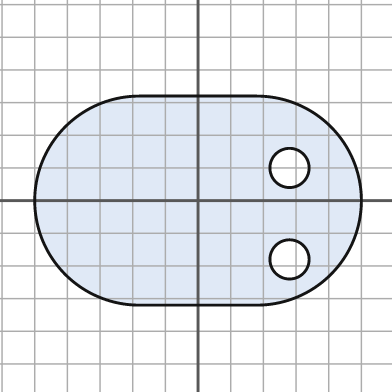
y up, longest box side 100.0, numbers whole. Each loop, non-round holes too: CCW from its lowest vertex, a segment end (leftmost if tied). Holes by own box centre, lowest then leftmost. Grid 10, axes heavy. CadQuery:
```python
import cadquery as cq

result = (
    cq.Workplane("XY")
    .moveTo(-18.0, -32.0)
    .lineTo(18.0, -32.0)
    .threePointArc((50.0, 0.0), (18.0, 32.0))
    .lineTo(-18.0, 32.0)
    .threePointArc((-50.0, 0.0), (-18.0, -32.0))
    .close()
    .moveTo(28.0, -18.0)
    .circle(6.0)
    .moveTo(28.0, 10.0)
    .circle(6.0)
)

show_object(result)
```